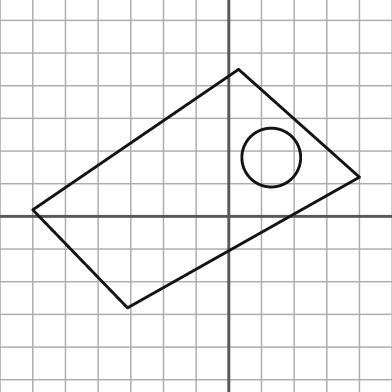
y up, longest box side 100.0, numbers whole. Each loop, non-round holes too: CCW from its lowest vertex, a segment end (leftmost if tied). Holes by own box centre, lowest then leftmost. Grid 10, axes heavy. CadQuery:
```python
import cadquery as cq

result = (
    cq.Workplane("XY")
    .moveTo(-31.0, -28.0)
    .lineTo(40.0, 12.0)
    .lineTo(3.0, 45.0)
    .lineTo(-60.0, 2.0)
    .close()
    .moveTo(13.0, 18.0)
    .circle(9.0)
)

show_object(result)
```